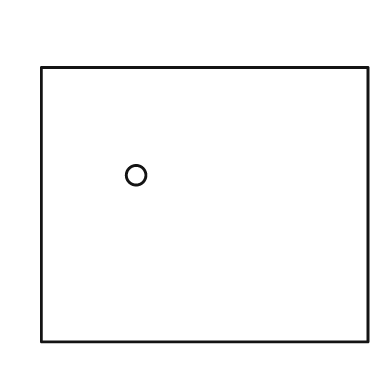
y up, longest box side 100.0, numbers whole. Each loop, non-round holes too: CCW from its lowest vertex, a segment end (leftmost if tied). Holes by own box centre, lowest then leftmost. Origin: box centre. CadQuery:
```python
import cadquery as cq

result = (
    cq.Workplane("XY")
    .moveTo(-50.0, -42.0)
    .lineTo(50.0, -42.0)
    .lineTo(50.0, 42.0)
    .lineTo(-50.0, 42.0)
    .close()
    .moveTo(-21.0, 9.0)
    .circle(3.0)
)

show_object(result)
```